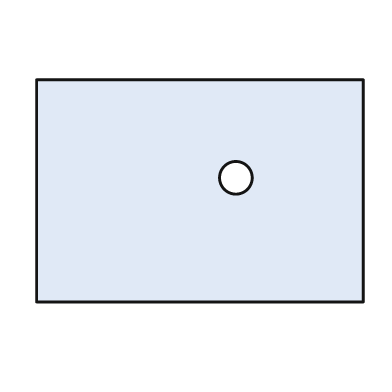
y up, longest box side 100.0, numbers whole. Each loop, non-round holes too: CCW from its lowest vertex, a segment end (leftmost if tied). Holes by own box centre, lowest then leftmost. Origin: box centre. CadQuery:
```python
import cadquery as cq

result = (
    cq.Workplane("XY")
    .moveTo(-50.0, -34.0)
    .lineTo(50.0, -34.0)
    .lineTo(50.0, 34.0)
    .lineTo(-50.0, 34.0)
    .close()
    .moveTo(11.0, 4.0)
    .circle(5.0)
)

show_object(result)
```